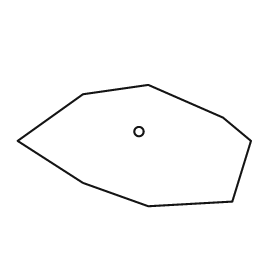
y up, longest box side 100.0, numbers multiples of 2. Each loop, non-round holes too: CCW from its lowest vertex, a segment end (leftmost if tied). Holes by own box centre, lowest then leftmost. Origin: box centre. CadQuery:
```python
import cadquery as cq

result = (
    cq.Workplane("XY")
    .moveTo(6.0, -26.0)
    .lineTo(42.0, -24.0)
    .lineTo(50.0, 2.0)
    .lineTo(38.0, 12.0)
    .lineTo(6.0, 26.0)
    .lineTo(-22.0, 22.0)
    .lineTo(-50.0, 2.0)
    .lineTo(-22.0, -16.0)
    .close()
    .moveTo(2.0, 6.0)
    .circle(2.0)
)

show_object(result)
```